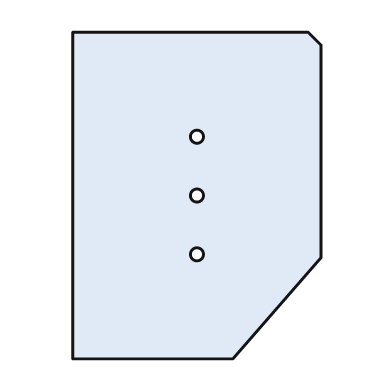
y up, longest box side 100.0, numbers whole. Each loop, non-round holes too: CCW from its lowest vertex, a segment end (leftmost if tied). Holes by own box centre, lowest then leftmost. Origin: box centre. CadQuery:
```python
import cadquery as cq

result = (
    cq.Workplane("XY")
    .moveTo(-38.0, -50.0)
    .lineTo(11.0, -50.0)
    .lineTo(38.0, -19.0)
    .lineTo(38.0, 46.0)
    .lineTo(34.0, 50.0)
    .lineTo(-38.0, 50.0)
    .close()
    .moveTo(0.0, -18.0)
    .circle(2.0)
    .moveTo(0.0, 0.0)
    .circle(2.0)
    .moveTo(0.0, 18.0)
    .circle(2.0)
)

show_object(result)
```